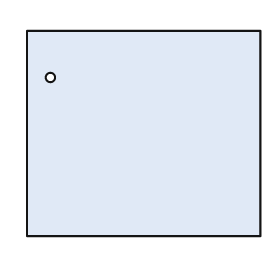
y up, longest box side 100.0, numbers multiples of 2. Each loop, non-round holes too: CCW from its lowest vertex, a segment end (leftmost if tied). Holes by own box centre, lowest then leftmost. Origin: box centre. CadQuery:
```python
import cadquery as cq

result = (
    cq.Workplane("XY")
    .moveTo(-50.0, -44.0)
    .lineTo(50.0, -44.0)
    .lineTo(50.0, 44.0)
    .lineTo(-50.0, 44.0)
    .close()
    .moveTo(-40.0, 24.0)
    .circle(2.0)
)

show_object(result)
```